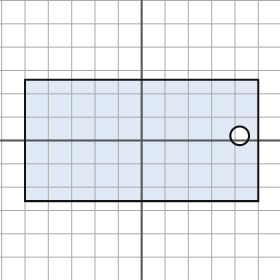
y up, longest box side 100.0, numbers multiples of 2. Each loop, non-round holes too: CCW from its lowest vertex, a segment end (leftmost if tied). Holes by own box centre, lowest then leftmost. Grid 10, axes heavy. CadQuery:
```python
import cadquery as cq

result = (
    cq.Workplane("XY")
    .moveTo(-50.0, -26.0)
    .lineTo(50.0, -26.0)
    .lineTo(50.0, 26.0)
    .lineTo(-50.0, 26.0)
    .close()
    .moveTo(42.0, 2.0)
    .circle(4.0)
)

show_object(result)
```